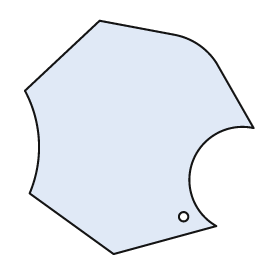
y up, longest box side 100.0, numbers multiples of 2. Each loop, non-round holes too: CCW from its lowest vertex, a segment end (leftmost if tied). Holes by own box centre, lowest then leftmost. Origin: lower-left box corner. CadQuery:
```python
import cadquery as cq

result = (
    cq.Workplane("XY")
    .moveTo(38.0, 0.0)
    .lineTo(82.0, 12.0)
    .threePointArc((72.0, 40.0), (98.0, 54.0))
    .lineTo(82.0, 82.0)
    .threePointArc((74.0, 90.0), (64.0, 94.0))
    .lineTo(32.0, 100.0)
    .lineTo(0.0, 70.0)
    .threePointArc((6.0, 48.0), (2.0, 26.0))
    .close()
    .moveTo(68.0, 16.0)
    .circle(2.0)
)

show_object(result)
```